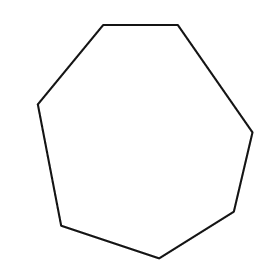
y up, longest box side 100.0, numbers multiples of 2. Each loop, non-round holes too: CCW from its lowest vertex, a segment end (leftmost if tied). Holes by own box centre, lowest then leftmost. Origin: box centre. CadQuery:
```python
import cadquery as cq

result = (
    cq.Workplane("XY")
    .moveTo(6.0, -50.0)
    .lineTo(38.0, -30.0)
    .lineTo(46.0, 4.0)
    .lineTo(14.0, 50.0)
    .lineTo(-18.0, 50.0)
    .lineTo(-46.0, 16.0)
    .lineTo(-36.0, -36.0)
    .close()
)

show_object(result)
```